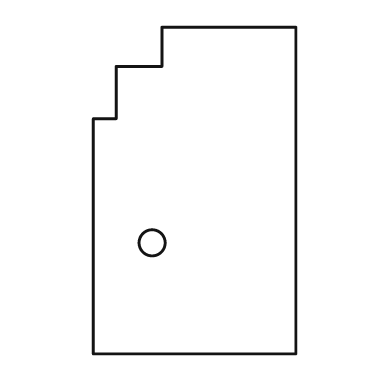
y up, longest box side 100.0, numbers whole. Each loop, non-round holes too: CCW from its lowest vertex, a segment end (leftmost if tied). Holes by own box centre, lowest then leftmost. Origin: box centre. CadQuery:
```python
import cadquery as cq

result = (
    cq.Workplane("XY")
    .moveTo(-31.0, -50.0)
    .lineTo(31.0, -50.0)
    .lineTo(31.0, 50.0)
    .lineTo(-10.0, 50.0)
    .lineTo(-10.0, 38.0)
    .lineTo(-24.0, 38.0)
    .lineTo(-24.0, 22.0)
    .lineTo(-31.0, 22.0)
    .close()
    .moveTo(-13.0, -16.0)
    .circle(4.0)
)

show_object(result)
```